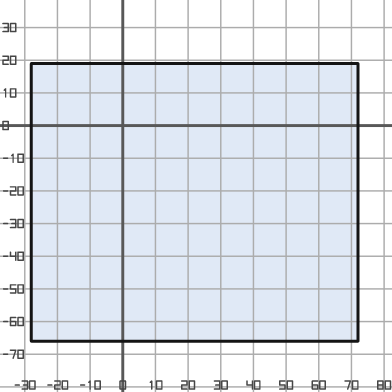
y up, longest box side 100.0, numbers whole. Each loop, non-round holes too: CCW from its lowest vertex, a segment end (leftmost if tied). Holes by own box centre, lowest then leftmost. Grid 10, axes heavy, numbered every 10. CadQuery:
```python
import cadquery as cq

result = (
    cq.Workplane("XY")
    .moveTo(-28.0, -66.0)
    .lineTo(72.0, -66.0)
    .lineTo(72.0, 19.0)
    .lineTo(-28.0, 19.0)
    .close()
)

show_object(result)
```